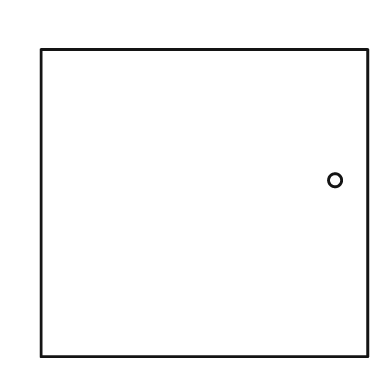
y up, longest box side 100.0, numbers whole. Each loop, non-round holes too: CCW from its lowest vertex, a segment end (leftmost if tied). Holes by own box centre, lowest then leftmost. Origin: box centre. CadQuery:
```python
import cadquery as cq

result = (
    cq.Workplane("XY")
    .moveTo(-50.0, -47.0)
    .lineTo(50.0, -47.0)
    .lineTo(50.0, 47.0)
    .lineTo(-50.0, 47.0)
    .close()
    .moveTo(40.0, 7.0)
    .circle(2.0)
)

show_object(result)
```